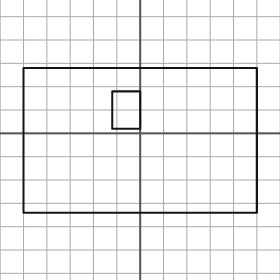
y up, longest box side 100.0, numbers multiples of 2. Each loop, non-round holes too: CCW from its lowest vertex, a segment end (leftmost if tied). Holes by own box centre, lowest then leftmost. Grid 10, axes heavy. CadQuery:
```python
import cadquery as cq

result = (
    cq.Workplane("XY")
    .moveTo(-50.0, -34.0)
    .lineTo(50.0, -34.0)
    .lineTo(50.0, 28.0)
    .lineTo(-50.0, 28.0)
    .close()
    .moveTo(-12.0, 2.0)
    .lineTo(0.0, 2.0)
    .lineTo(0.0, 18.0)
    .lineTo(-12.0, 18.0)
    .close()
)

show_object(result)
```